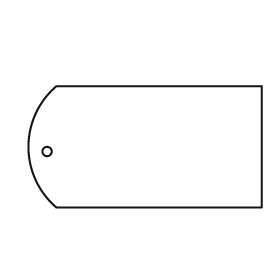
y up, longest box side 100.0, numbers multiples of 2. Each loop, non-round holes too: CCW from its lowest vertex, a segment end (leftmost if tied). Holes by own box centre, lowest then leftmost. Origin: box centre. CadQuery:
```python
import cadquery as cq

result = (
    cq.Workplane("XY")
    .moveTo(-38.0, -26.0)
    .lineTo(50.0, -26.0)
    .lineTo(50.0, 26.0)
    .lineTo(-38.0, 26.0)
    .threePointArc((-50.0, 0.0), (-38.0, -26.0))
    .close()
    .moveTo(-42.0, -2.0)
    .circle(2.0)
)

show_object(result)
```